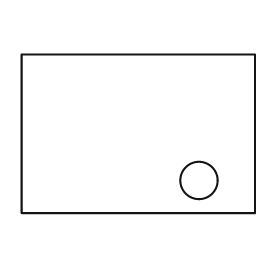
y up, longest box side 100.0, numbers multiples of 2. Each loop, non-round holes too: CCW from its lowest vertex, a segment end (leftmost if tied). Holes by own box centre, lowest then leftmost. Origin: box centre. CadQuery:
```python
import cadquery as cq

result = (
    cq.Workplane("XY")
    .moveTo(-50.0, -34.0)
    .lineTo(50.0, -34.0)
    .lineTo(50.0, 34.0)
    .lineTo(-50.0, 34.0)
    .close()
    .moveTo(26.0, -20.0)
    .circle(8.0)
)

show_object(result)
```